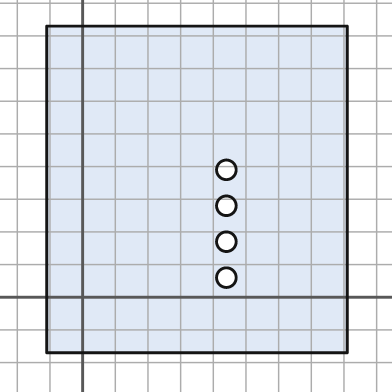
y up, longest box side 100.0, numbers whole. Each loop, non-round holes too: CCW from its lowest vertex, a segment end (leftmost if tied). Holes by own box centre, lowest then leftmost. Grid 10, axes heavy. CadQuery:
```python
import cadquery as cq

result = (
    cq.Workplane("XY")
    .moveTo(-11.0, -17.0)
    .lineTo(81.0, -17.0)
    .lineTo(81.0, 83.0)
    .lineTo(-11.0, 83.0)
    .close()
    .moveTo(44.0, 6.0)
    .circle(3.0)
    .moveTo(44.0, 17.0)
    .circle(3.0)
    .moveTo(44.0, 28.0)
    .circle(3.0)
    .moveTo(44.0, 39.0)
    .circle(3.0)
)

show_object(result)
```